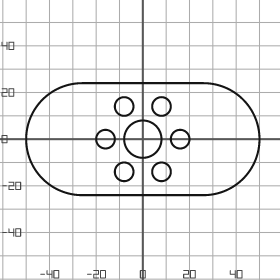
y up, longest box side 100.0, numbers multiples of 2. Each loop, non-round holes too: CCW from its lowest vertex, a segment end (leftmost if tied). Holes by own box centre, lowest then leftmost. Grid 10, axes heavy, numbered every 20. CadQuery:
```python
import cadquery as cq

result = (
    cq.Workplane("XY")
    .moveTo(-26.0, -24.0)
    .lineTo(26.0, -24.0)
    .threePointArc((50.0, 0.0), (26.0, 24.0))
    .lineTo(-26.0, 24.0)
    .threePointArc((-50.0, 0.0), (-26.0, -24.0))
    .close()
    .moveTo(-8.0, -14.0)
    .circle(4.0)
    .moveTo(8.0, -14.0)
    .circle(4.0)
    .moveTo(-16.0, 0.0)
    .circle(4.0)
    .moveTo(0.0, 0.0)
    .circle(8.0)
    .moveTo(16.0, 0.0)
    .circle(4.0)
    .moveTo(-8.0, 14.0)
    .circle(4.0)
    .moveTo(8.0, 14.0)
    .circle(4.0)
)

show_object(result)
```